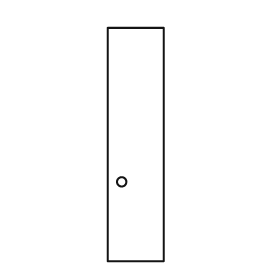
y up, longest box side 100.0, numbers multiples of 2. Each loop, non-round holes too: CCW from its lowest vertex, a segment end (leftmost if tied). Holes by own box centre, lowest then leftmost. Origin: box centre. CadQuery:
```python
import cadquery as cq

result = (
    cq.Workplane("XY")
    .moveTo(-12.0, -50.0)
    .lineTo(12.0, -50.0)
    .lineTo(12.0, 50.0)
    .lineTo(-12.0, 50.0)
    .close()
    .moveTo(-6.0, -16.0)
    .circle(2.0)
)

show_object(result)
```